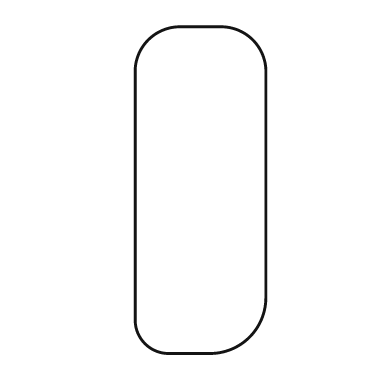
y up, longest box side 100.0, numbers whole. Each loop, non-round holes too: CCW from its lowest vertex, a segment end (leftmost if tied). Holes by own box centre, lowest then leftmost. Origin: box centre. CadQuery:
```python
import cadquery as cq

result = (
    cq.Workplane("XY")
    .moveTo(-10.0, -50.0)
    .lineTo(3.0, -50.0)
    .threePointArc((15.0, -45.0), (20.0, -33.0))
    .lineTo(20.0, 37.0)
    .threePointArc((16.0, 46.0), (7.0, 50.0))
    .lineTo(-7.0, 50.0)
    .threePointArc((-16.0, 46.0), (-20.0, 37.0))
    .lineTo(-20.0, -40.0)
    .threePointArc((-17.0, -47.0), (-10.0, -50.0))
    .close()
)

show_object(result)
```